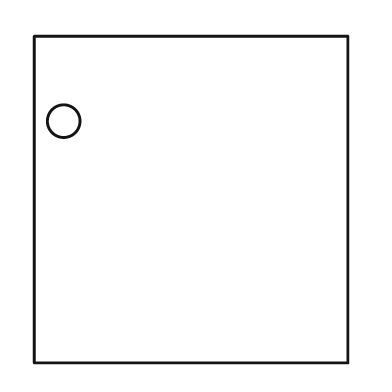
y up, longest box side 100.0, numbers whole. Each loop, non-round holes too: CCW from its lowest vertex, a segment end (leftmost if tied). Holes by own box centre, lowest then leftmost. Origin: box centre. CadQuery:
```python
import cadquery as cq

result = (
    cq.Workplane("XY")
    .moveTo(-48.0, -50.0)
    .lineTo(48.0, -50.0)
    .lineTo(48.0, 50.0)
    .lineTo(-48.0, 50.0)
    .close()
    .moveTo(-39.0, 24.0)
    .circle(5.0)
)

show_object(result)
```